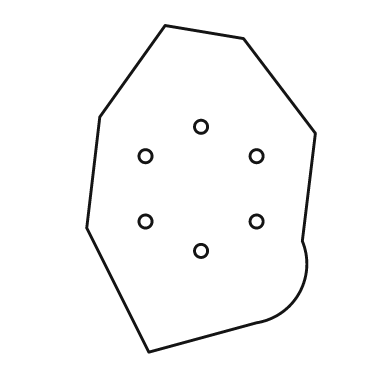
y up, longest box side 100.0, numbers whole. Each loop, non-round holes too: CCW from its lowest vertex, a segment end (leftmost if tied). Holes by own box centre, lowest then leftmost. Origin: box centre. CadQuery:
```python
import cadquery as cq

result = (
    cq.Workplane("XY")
    .moveTo(-16.0, -50.0)
    .lineTo(17.0, -41.0)
    .threePointArc((30.0, -32.0), (31.0, -16.0))
    .lineTo(35.0, 17.0)
    .lineTo(13.0, 46.0)
    .lineTo(-11.0, 50.0)
    .lineTo(-31.0, 22.0)
    .lineTo(-35.0, -12.0)
    .close()
    .moveTo(0.0, -19.0)
    .circle(2.0)
    .moveTo(-17.0, -10.0)
    .circle(2.0)
    .moveTo(17.0, -10.0)
    .circle(2.0)
    .moveTo(-17.0, 10.0)
    .circle(2.0)
    .moveTo(17.0, 10.0)
    .circle(2.0)
    .moveTo(0.0, 19.0)
    .circle(2.0)
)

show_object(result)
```